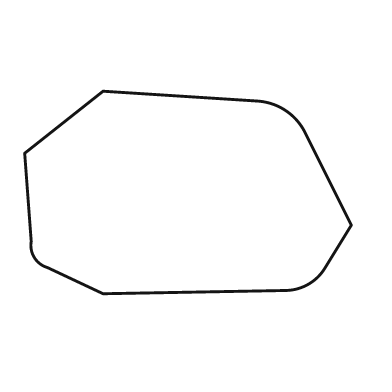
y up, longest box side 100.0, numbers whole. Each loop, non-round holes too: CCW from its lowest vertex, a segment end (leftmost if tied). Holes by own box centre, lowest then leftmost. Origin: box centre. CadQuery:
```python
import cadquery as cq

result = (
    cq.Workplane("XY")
    .moveTo(-26.0, -31.0)
    .lineTo(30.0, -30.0)
    .threePointArc((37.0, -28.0), (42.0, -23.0))
    .lineTo(50.0, -10.0)
    .lineTo(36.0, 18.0)
    .threePointArc((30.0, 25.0), (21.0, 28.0))
    .lineTo(-26.0, 31.0)
    .lineTo(-50.0, 12.0)
    .lineTo(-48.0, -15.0)
    .threePointArc((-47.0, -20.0), (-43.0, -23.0))
    .close()
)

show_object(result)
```